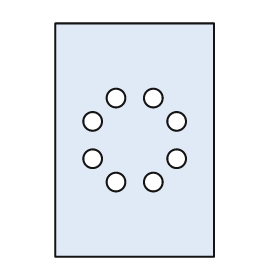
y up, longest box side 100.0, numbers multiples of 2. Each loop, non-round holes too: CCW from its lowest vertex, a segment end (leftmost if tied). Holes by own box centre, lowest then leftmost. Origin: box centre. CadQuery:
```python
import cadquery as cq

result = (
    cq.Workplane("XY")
    .moveTo(-34.0, -50.0)
    .lineTo(34.0, -50.0)
    .lineTo(34.0, 50.0)
    .lineTo(-34.0, 50.0)
    .close()
    .moveTo(-8.0, -18.0)
    .circle(4.0)
    .moveTo(8.0, -18.0)
    .circle(4.0)
    .moveTo(-18.0, -8.0)
    .circle(4.0)
    .moveTo(18.0, -8.0)
    .circle(4.0)
    .moveTo(-18.0, 8.0)
    .circle(4.0)
    .moveTo(18.0, 8.0)
    .circle(4.0)
    .moveTo(-8.0, 18.0)
    .circle(4.0)
    .moveTo(8.0, 18.0)
    .circle(4.0)
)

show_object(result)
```